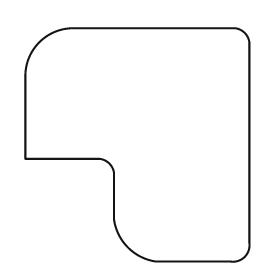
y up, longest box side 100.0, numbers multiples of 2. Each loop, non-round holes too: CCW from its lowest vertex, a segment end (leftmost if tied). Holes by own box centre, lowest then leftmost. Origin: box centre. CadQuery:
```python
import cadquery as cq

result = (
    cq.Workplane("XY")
    .moveTo(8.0, -50.0)
    .lineTo(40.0, -50.0)
    .threePointArc((46.0, -48.0), (48.0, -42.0))
    .lineTo(48.0, 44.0)
    .threePointArc((46.0, 48.0), (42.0, 50.0))
    .lineTo(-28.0, 50.0)
    .threePointArc((-42.0, 44.0), (-48.0, 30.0))
    .lineTo(-48.0, -6.0)
    .lineTo(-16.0, -6.0)
    .threePointArc((-12.0, -8.0), (-10.0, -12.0))
    .lineTo(-10.0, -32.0)
    .threePointArc((-4.0, -44.0), (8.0, -50.0))
    .close()
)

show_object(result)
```